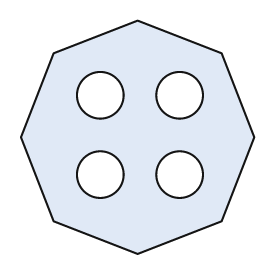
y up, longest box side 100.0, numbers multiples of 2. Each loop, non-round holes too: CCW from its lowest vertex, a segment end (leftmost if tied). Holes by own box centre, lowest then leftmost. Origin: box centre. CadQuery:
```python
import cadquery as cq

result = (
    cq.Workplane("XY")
    .moveTo(0.0, -50.0)
    .lineTo(36.0, -36.0)
    .lineTo(50.0, 0.0)
    .lineTo(36.0, 36.0)
    .lineTo(0.0, 50.0)
    .lineTo(-36.0, 36.0)
    .lineTo(-50.0, 0.0)
    .lineTo(-36.0, -36.0)
    .close()
    .moveTo(-16.0, -16.0)
    .circle(10.0)
    .moveTo(18.0, -16.0)
    .circle(10.0)
    .moveTo(-16.0, 18.0)
    .circle(10.0)
    .moveTo(18.0, 18.0)
    .circle(10.0)
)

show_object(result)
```